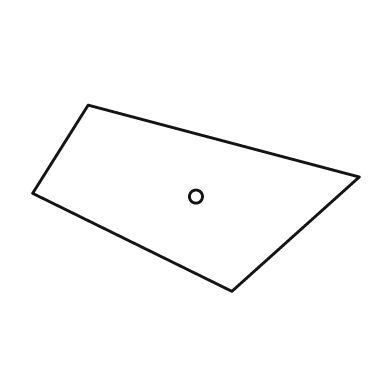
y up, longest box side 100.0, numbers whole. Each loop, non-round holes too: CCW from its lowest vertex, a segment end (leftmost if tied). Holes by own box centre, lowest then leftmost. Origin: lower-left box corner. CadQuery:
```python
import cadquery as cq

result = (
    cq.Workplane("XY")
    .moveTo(61.0, 0.0)
    .lineTo(100.0, 35.0)
    .lineTo(17.0, 57.0)
    .lineTo(0.0, 30.0)
    .close()
    .moveTo(50.0, 29.0)
    .circle(2.0)
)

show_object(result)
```